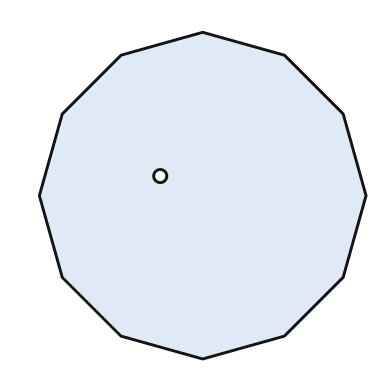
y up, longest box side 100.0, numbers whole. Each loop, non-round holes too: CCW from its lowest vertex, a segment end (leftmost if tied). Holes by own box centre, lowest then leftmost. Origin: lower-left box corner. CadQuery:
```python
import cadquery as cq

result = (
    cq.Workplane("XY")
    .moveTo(50.0, 0.0)
    .lineTo(75.0, 7.0)
    .lineTo(93.0, 25.0)
    .lineTo(100.0, 50.0)
    .lineTo(93.0, 75.0)
    .lineTo(75.0, 93.0)
    .lineTo(50.0, 100.0)
    .lineTo(25.0, 93.0)
    .lineTo(7.0, 75.0)
    .lineTo(0.0, 50.0)
    .lineTo(7.0, 25.0)
    .lineTo(25.0, 7.0)
    .close()
    .moveTo(37.0, 56.0)
    .circle(2.0)
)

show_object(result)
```